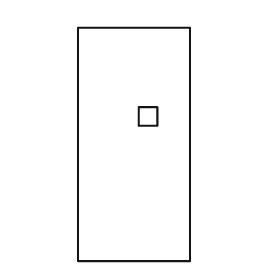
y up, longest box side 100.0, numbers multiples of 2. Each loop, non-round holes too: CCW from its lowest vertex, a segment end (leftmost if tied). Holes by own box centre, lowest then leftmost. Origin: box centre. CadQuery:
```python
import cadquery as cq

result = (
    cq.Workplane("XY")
    .moveTo(-24.0, -50.0)
    .lineTo(24.0, -50.0)
    .lineTo(24.0, 50.0)
    .lineTo(-24.0, 50.0)
    .close()
    .moveTo(2.0, 8.0)
    .lineTo(10.0, 8.0)
    .lineTo(10.0, 16.0)
    .lineTo(2.0, 16.0)
    .close()
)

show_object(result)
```